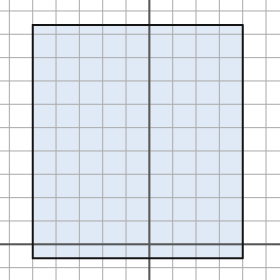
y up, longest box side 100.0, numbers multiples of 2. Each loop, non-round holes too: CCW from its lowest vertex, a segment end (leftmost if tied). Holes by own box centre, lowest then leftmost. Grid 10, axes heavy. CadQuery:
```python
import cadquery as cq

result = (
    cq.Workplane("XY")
    .moveTo(-50.0, -6.0)
    .lineTo(40.0, -6.0)
    .lineTo(40.0, 94.0)
    .lineTo(-50.0, 94.0)
    .close()
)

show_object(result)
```